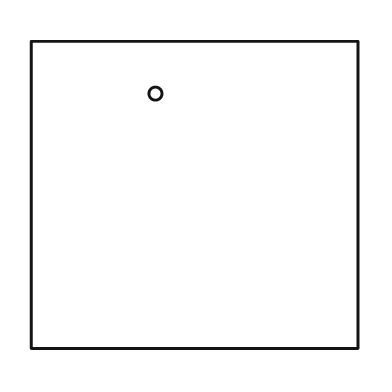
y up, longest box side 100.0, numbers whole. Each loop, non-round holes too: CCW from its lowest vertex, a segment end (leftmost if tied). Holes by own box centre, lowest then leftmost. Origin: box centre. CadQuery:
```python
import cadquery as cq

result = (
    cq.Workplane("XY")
    .moveTo(-50.0, -47.0)
    .lineTo(50.0, -47.0)
    .lineTo(50.0, 47.0)
    .lineTo(-50.0, 47.0)
    .close()
    .moveTo(-12.0, 31.0)
    .circle(2.0)
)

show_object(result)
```